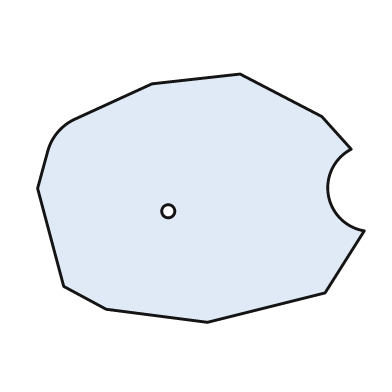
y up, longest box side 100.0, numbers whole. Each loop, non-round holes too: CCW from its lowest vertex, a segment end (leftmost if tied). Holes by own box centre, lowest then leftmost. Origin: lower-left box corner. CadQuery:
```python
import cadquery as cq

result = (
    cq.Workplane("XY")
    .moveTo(52.0, 0.0)
    .lineTo(88.0, 9.0)
    .lineTo(100.0, 28.0)
    .threePointArc((89.0, 39.0), (96.0, 53.0))
    .lineTo(87.0, 63.0)
    .lineTo(62.0, 76.0)
    .lineTo(35.0, 73.0)
    .lineTo(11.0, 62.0)
    .threePointArc((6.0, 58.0), (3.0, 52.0))
    .lineTo(0.0, 41.0)
    .lineTo(8.0, 11.0)
    .lineTo(21.0, 4.0)
    .close()
    .moveTo(40.0, 34.0)
    .circle(2.0)
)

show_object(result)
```